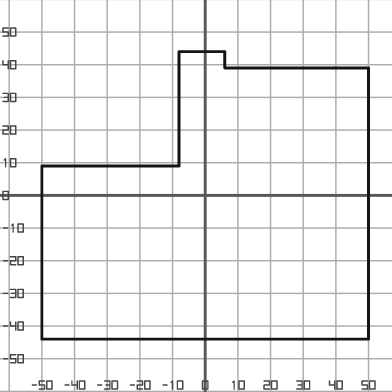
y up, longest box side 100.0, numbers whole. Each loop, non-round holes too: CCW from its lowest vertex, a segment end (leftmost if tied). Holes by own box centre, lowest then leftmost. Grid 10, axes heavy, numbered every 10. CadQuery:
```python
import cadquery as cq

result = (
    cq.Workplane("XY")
    .moveTo(-50.0, -44.0)
    .lineTo(50.0, -44.0)
    .lineTo(50.0, 39.0)
    .lineTo(6.0, 39.0)
    .lineTo(6.0, 44.0)
    .lineTo(-8.0, 44.0)
    .lineTo(-8.0, 9.0)
    .lineTo(-50.0, 9.0)
    .close()
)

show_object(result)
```